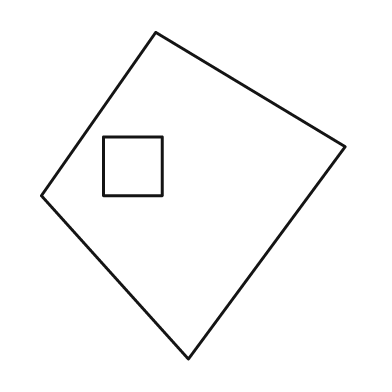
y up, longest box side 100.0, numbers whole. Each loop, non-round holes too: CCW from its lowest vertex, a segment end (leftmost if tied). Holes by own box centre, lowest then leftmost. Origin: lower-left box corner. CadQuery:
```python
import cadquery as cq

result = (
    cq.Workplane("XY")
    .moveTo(45.0, 0.0)
    .lineTo(93.0, 65.0)
    .lineTo(35.0, 100.0)
    .lineTo(0.0, 50.0)
    .close()
    .moveTo(19.0, 50.0)
    .lineTo(37.0, 50.0)
    .lineTo(37.0, 68.0)
    .lineTo(19.0, 68.0)
    .close()
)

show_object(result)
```